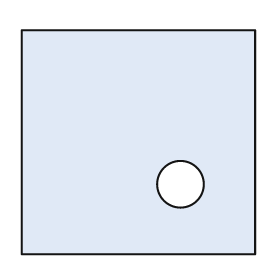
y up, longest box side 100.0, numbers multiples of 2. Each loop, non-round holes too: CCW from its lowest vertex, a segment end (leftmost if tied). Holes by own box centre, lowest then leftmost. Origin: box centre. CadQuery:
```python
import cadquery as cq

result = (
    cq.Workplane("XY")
    .moveTo(-50.0, -48.0)
    .lineTo(50.0, -48.0)
    .lineTo(50.0, 48.0)
    .lineTo(-50.0, 48.0)
    .close()
    .moveTo(18.0, -18.0)
    .circle(10.0)
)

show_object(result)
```